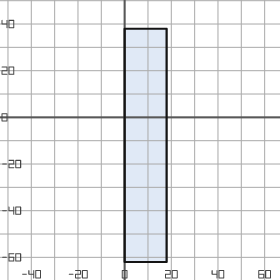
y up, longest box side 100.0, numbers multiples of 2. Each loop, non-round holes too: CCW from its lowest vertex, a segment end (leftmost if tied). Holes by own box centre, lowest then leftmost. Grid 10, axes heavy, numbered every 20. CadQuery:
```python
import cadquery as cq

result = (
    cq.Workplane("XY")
    .moveTo(0.0, -62.0)
    .lineTo(18.0, -62.0)
    .lineTo(18.0, 38.0)
    .lineTo(0.0, 38.0)
    .close()
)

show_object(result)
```